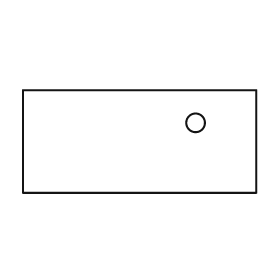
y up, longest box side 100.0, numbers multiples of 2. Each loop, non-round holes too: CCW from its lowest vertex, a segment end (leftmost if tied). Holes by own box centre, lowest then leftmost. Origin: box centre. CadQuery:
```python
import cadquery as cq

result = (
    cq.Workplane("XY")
    .moveTo(-50.0, -22.0)
    .lineTo(50.0, -22.0)
    .lineTo(50.0, 22.0)
    .lineTo(-50.0, 22.0)
    .close()
    .moveTo(24.0, 8.0)
    .circle(4.0)
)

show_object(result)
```